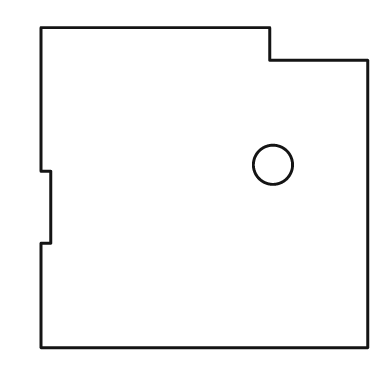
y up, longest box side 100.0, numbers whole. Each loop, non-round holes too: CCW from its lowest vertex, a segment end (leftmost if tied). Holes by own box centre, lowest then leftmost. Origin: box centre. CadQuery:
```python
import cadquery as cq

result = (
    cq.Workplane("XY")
    .moveTo(-50.0, -49.0)
    .lineTo(50.0, -49.0)
    .lineTo(50.0, 39.0)
    .lineTo(20.0, 39.0)
    .lineTo(20.0, 49.0)
    .lineTo(-50.0, 49.0)
    .lineTo(-50.0, 5.0)
    .lineTo(-47.0, 5.0)
    .lineTo(-47.0, -17.0)
    .lineTo(-50.0, -17.0)
    .close()
    .moveTo(21.0, 7.0)
    .circle(6.0)
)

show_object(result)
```